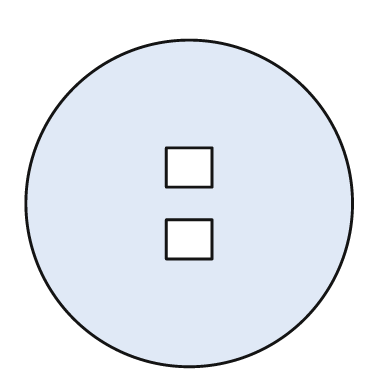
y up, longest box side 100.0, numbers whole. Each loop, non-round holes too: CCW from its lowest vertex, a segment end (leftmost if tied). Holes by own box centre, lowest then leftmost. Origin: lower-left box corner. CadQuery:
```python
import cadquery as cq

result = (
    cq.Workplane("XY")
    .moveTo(50.0, 50.0)
    .circle(50.0)
    .moveTo(43.0, 33.0)
    .lineTo(57.0, 33.0)
    .lineTo(57.0, 45.0)
    .lineTo(43.0, 45.0)
    .close()
    .moveTo(43.0, 55.0)
    .lineTo(57.0, 55.0)
    .lineTo(57.0, 67.0)
    .lineTo(43.0, 67.0)
    .close()
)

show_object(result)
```